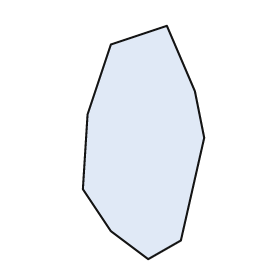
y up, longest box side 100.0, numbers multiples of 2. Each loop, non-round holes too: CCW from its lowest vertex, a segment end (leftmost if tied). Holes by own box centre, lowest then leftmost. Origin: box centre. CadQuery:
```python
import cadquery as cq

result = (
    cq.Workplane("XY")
    .moveTo(2.0, -50.0)
    .lineTo(16.0, -42.0)
    .lineTo(26.0, 2.0)
    .lineTo(22.0, 22.0)
    .lineTo(10.0, 50.0)
    .lineTo(-14.0, 42.0)
    .lineTo(-24.0, 12.0)
    .lineTo(-26.0, -20.0)
    .lineTo(-14.0, -38.0)
    .close()
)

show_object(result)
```